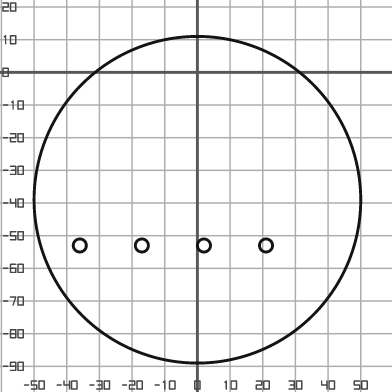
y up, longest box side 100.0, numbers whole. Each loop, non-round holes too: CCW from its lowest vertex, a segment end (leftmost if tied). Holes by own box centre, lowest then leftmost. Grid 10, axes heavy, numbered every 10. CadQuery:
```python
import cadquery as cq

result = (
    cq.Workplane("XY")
    .moveTo(0.0, -39.0)
    .circle(50.0)
    .moveTo(-36.0, -53.0)
    .circle(2.0)
    .moveTo(-17.0, -53.0)
    .circle(2.0)
    .moveTo(2.0, -53.0)
    .circle(2.0)
    .moveTo(21.0, -53.0)
    .circle(2.0)
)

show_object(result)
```